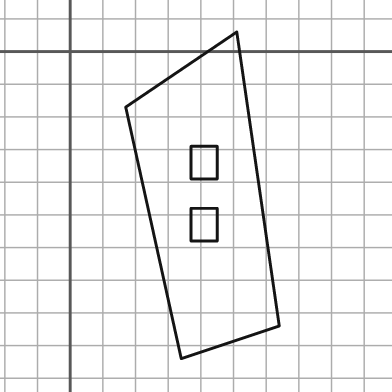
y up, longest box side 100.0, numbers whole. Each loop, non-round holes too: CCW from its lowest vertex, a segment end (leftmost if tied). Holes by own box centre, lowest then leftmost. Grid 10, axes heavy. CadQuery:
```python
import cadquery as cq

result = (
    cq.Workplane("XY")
    .moveTo(34.0, -94.0)
    .lineTo(64.0, -84.0)
    .lineTo(51.0, 6.0)
    .lineTo(17.0, -17.0)
    .close()
    .moveTo(37.0, -58.0)
    .lineTo(45.0, -58.0)
    .lineTo(45.0, -48.0)
    .lineTo(37.0, -48.0)
    .close()
    .moveTo(37.0, -39.0)
    .lineTo(45.0, -39.0)
    .lineTo(45.0, -29.0)
    .lineTo(37.0, -29.0)
    .close()
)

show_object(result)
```